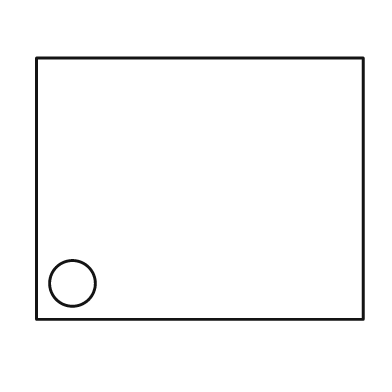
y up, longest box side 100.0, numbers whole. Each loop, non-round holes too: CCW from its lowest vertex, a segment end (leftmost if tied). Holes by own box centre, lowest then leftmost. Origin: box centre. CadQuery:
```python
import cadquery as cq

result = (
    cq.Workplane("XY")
    .moveTo(-50.0, -40.0)
    .lineTo(50.0, -40.0)
    .lineTo(50.0, 40.0)
    .lineTo(-50.0, 40.0)
    .close()
    .moveTo(-39.0, -29.0)
    .circle(7.0)
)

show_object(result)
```